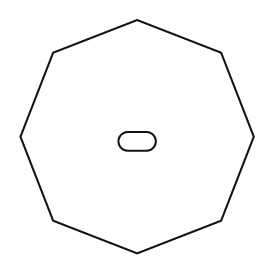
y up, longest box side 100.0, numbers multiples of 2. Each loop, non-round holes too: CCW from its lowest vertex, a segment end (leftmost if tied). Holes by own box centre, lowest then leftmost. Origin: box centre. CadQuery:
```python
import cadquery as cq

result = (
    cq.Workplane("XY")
    .moveTo(0.0, -50.0)
    .lineTo(36.0, -36.0)
    .lineTo(50.0, 0.0)
    .lineTo(36.0, 36.0)
    .lineTo(0.0, 50.0)
    .lineTo(-36.0, 36.0)
    .lineTo(-50.0, 0.0)
    .lineTo(-36.0, -36.0)
    .close()
    .moveTo(-4.0, -6.0)
    .lineTo(4.0, -6.0)
    .threePointArc((8.0, -2.0), (4.0, 2.0))
    .lineTo(-4.0, 2.0)
    .threePointArc((-8.0, -2.0), (-4.0, -6.0))
    .close()
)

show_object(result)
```